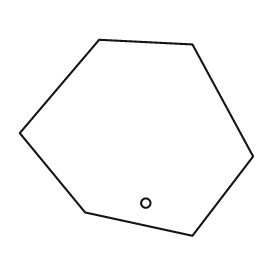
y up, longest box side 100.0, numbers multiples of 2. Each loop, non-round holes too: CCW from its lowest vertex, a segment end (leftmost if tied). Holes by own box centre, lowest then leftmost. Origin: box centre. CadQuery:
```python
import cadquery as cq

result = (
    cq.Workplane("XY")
    .moveTo(24.0, -42.0)
    .lineTo(50.0, -8.0)
    .lineTo(24.0, 40.0)
    .lineTo(-16.0, 42.0)
    .lineTo(-50.0, 2.0)
    .lineTo(-22.0, -32.0)
    .close()
    .moveTo(4.0, -28.0)
    .circle(2.0)
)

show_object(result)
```